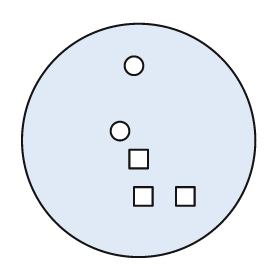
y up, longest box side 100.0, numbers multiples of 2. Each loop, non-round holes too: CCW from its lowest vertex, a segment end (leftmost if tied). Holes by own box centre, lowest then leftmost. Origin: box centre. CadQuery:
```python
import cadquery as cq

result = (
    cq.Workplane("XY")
    .moveTo(0.0, 0.0)
    .circle(50.0)
    .moveTo(-2.0, -28.0)
    .lineTo(6.0, -28.0)
    .lineTo(6.0, -20.0)
    .lineTo(-2.0, -20.0)
    .close()
    .moveTo(16.0, -28.0)
    .lineTo(24.0, -28.0)
    .lineTo(24.0, -20.0)
    .lineTo(16.0, -20.0)
    .close()
    .moveTo(-4.0, -12.0)
    .lineTo(4.0, -12.0)
    .lineTo(4.0, -4.0)
    .lineTo(-4.0, -4.0)
    .close()
    .moveTo(-8.0, 4.0)
    .circle(4.0)
    .moveTo(-2.0, 32.0)
    .circle(4.0)
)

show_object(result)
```